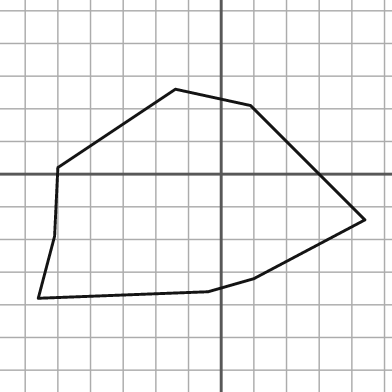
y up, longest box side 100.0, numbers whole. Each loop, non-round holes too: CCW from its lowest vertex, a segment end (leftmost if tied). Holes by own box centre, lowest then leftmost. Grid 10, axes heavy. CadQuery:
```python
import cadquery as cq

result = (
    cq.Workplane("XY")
    .moveTo(-56.0, -38.0)
    .lineTo(-4.0, -36.0)
    .lineTo(10.0, -32.0)
    .lineTo(44.0, -14.0)
    .lineTo(9.0, 21.0)
    .lineTo(-14.0, 26.0)
    .lineTo(-50.0, 2.0)
    .lineTo(-51.0, -19.0)
    .close()
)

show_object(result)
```